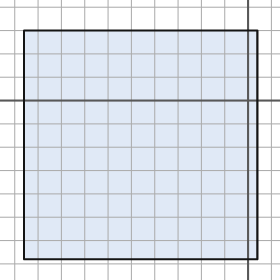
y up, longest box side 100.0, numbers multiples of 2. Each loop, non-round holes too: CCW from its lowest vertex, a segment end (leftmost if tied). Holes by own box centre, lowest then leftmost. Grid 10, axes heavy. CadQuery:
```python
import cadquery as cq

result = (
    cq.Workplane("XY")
    .moveTo(-96.0, -68.0)
    .lineTo(4.0, -68.0)
    .lineTo(4.0, 30.0)
    .lineTo(-96.0, 30.0)
    .close()
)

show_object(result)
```